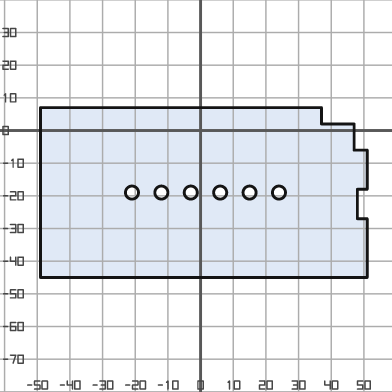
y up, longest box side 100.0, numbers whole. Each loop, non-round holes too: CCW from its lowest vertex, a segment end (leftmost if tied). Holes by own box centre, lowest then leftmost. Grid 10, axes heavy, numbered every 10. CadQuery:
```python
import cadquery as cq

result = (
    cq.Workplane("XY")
    .moveTo(-49.0, -45.0)
    .lineTo(51.0, -45.0)
    .lineTo(51.0, -27.0)
    .lineTo(48.0, -27.0)
    .lineTo(48.0, -18.0)
    .lineTo(51.0, -18.0)
    .lineTo(51.0, -6.0)
    .lineTo(47.0, -6.0)
    .lineTo(47.0, 2.0)
    .lineTo(37.0, 2.0)
    .lineTo(37.0, 7.0)
    .lineTo(-49.0, 7.0)
    .close()
    .moveTo(-21.0, -19.0)
    .circle(2.0)
    .moveTo(-12.0, -19.0)
    .circle(2.0)
    .moveTo(-3.0, -19.0)
    .circle(2.0)
    .moveTo(6.0, -19.0)
    .circle(2.0)
    .moveTo(15.0, -19.0)
    .circle(2.0)
    .moveTo(24.0, -19.0)
    .circle(2.0)
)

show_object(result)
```